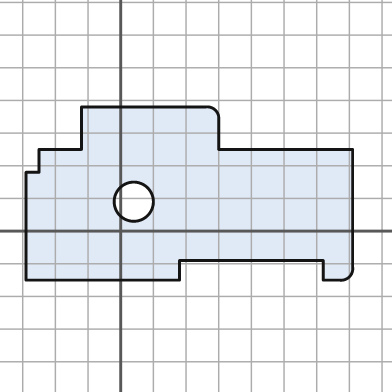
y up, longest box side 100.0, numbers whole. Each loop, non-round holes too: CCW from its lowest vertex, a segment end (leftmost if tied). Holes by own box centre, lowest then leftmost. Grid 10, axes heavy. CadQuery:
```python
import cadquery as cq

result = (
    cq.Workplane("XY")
    .moveTo(-29.0, -15.0)
    .lineTo(18.0, -15.0)
    .lineTo(18.0, -9.0)
    .lineTo(62.0, -9.0)
    .lineTo(62.0, -15.0)
    .lineTo(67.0, -15.0)
    .threePointArc((70.0, -14.0), (71.0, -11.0))
    .lineTo(71.0, 25.0)
    .lineTo(30.0, 25.0)
    .lineTo(30.0, 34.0)
    .threePointArc((29.0, 37.0), (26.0, 38.0))
    .lineTo(-12.0, 38.0)
    .lineTo(-12.0, 25.0)
    .lineTo(-25.0, 25.0)
    .lineTo(-25.0, 18.0)
    .lineTo(-29.0, 18.0)
    .close()
    .moveTo(4.0, 9.0)
    .circle(6.0)
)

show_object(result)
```